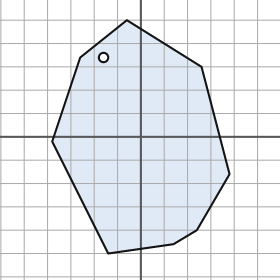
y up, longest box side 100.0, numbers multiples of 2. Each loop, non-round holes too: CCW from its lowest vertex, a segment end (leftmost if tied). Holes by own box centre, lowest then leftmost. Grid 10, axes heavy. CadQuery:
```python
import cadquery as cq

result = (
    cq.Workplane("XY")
    .moveTo(-14.0, -50.0)
    .lineTo(14.0, -46.0)
    .lineTo(24.0, -40.0)
    .lineTo(38.0, -16.0)
    .lineTo(26.0, 30.0)
    .lineTo(-6.0, 50.0)
    .lineTo(-26.0, 34.0)
    .lineTo(-38.0, -2.0)
    .close()
    .moveTo(-16.0, 34.0)
    .circle(2.0)
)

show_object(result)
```